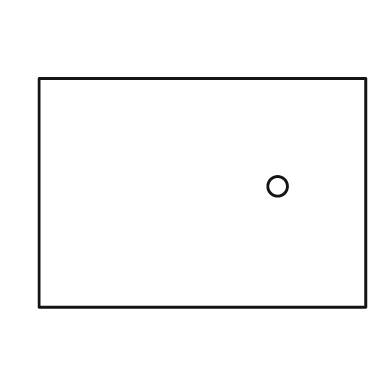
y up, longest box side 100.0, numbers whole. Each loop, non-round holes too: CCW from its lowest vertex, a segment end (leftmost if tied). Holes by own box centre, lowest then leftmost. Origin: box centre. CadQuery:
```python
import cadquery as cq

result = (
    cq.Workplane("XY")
    .moveTo(-50.0, -35.0)
    .lineTo(50.0, -35.0)
    .lineTo(50.0, 35.0)
    .lineTo(-50.0, 35.0)
    .close()
    .moveTo(23.0, 2.0)
    .circle(3.0)
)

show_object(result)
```